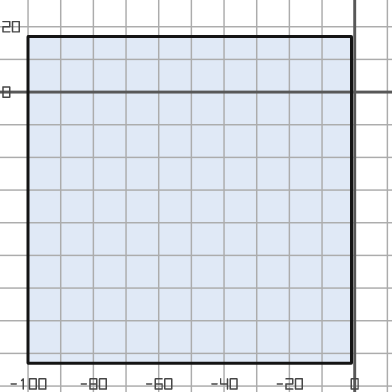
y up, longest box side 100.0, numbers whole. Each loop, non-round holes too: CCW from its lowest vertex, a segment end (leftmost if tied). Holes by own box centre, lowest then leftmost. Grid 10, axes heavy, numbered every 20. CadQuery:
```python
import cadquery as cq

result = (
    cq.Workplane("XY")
    .moveTo(-100.0, -83.0)
    .lineTo(-1.0, -83.0)
    .lineTo(-1.0, 17.0)
    .lineTo(-100.0, 17.0)
    .close()
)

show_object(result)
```